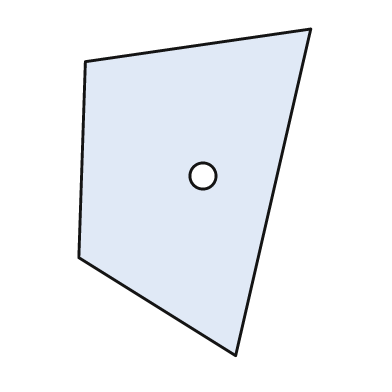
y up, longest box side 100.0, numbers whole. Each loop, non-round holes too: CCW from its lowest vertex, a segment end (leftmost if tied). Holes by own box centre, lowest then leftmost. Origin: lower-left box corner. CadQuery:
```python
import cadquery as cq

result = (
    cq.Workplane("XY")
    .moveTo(48.0, 0.0)
    .lineTo(71.0, 100.0)
    .lineTo(2.0, 90.0)
    .lineTo(0.0, 30.0)
    .close()
    .moveTo(38.0, 55.0)
    .circle(4.0)
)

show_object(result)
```